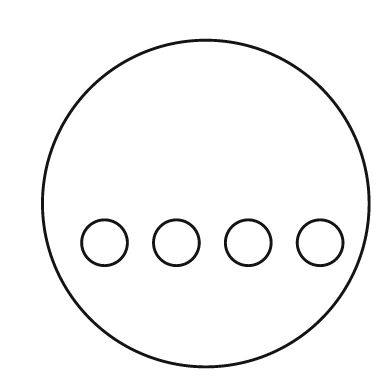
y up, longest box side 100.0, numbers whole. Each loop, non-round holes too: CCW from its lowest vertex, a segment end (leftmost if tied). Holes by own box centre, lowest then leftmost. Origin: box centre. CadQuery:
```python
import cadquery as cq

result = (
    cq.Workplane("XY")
    .moveTo(0.0, 0.0)
    .circle(50.0)
    .moveTo(-31.0, -12.0)
    .circle(7.0)
    .moveTo(-9.0, -12.0)
    .circle(7.0)
    .moveTo(13.0, -12.0)
    .circle(7.0)
    .moveTo(35.0, -12.0)
    .circle(7.0)
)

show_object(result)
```